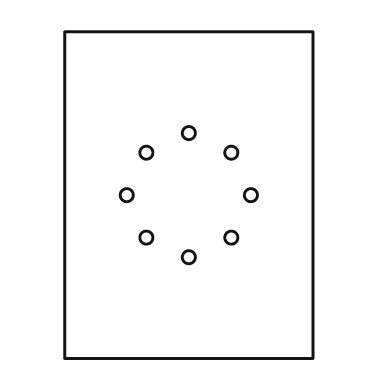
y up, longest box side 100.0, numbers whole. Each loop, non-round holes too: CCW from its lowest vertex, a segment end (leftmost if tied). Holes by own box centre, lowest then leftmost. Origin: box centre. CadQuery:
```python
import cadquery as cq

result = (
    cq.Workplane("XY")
    .moveTo(-38.0, -50.0)
    .lineTo(38.0, -50.0)
    .lineTo(38.0, 50.0)
    .lineTo(-38.0, 50.0)
    .close()
    .moveTo(0.0, -19.0)
    .circle(2.0)
    .moveTo(-13.0, -13.0)
    .circle(2.0)
    .moveTo(13.0, -13.0)
    .circle(2.0)
    .moveTo(-19.0, 0.0)
    .circle(2.0)
    .moveTo(19.0, 0.0)
    .circle(2.0)
    .moveTo(-13.0, 13.0)
    .circle(2.0)
    .moveTo(13.0, 13.0)
    .circle(2.0)
    .moveTo(0.0, 19.0)
    .circle(2.0)
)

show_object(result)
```